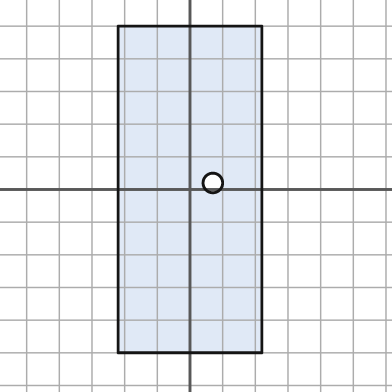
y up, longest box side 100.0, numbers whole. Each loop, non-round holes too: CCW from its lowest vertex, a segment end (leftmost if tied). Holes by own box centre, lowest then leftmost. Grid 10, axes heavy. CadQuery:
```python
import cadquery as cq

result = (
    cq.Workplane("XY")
    .moveTo(-22.0, -50.0)
    .lineTo(22.0, -50.0)
    .lineTo(22.0, 50.0)
    .lineTo(-22.0, 50.0)
    .close()
    .moveTo(7.0, 2.0)
    .circle(3.0)
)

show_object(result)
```